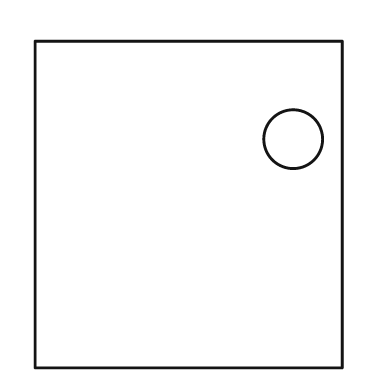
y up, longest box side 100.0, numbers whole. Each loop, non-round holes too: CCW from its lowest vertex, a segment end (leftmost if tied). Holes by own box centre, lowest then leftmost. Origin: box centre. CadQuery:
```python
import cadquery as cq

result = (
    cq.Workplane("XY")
    .moveTo(-47.0, -50.0)
    .lineTo(47.0, -50.0)
    .lineTo(47.0, 50.0)
    .lineTo(-47.0, 50.0)
    .close()
    .moveTo(32.0, 20.0)
    .circle(9.0)
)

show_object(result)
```